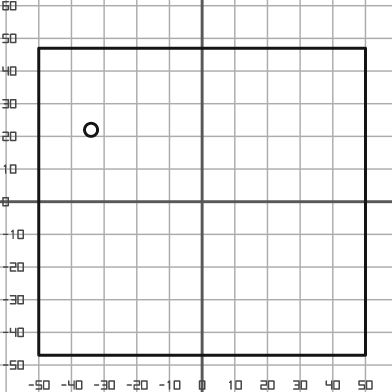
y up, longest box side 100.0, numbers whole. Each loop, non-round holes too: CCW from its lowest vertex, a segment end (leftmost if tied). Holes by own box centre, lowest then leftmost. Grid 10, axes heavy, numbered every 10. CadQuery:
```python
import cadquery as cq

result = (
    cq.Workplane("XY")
    .moveTo(-50.0, -47.0)
    .lineTo(50.0, -47.0)
    .lineTo(50.0, 47.0)
    .lineTo(-50.0, 47.0)
    .close()
    .moveTo(-34.0, 22.0)
    .circle(2.0)
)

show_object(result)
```